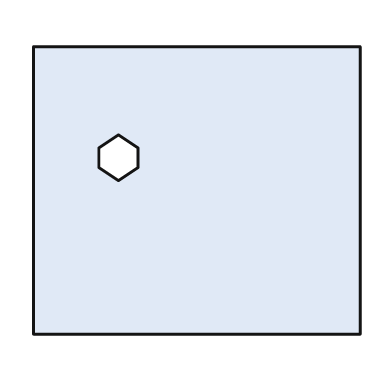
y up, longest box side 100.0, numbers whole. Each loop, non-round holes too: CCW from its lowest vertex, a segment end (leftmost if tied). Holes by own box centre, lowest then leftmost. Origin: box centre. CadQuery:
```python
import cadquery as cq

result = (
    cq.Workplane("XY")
    .moveTo(-50.0, -44.0)
    .lineTo(50.0, -44.0)
    .lineTo(50.0, 44.0)
    .lineTo(-50.0, 44.0)
    .close()
    .moveTo(-24.0, 3.0)
    .lineTo(-18.0, 7.0)
    .lineTo(-18.0, 13.0)
    .lineTo(-24.0, 17.0)
    .lineTo(-30.0, 13.0)
    .lineTo(-30.0, 7.0)
    .close()
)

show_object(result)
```